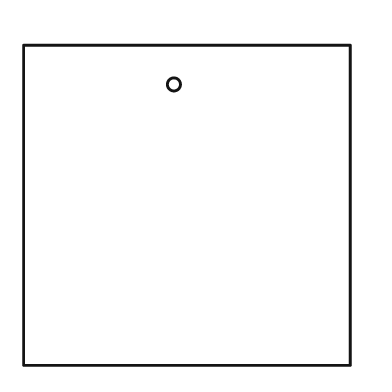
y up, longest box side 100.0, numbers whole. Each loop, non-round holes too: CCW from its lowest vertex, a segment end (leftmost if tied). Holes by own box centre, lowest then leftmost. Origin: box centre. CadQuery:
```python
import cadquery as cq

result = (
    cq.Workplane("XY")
    .moveTo(-50.0, -49.0)
    .lineTo(50.0, -49.0)
    .lineTo(50.0, 49.0)
    .lineTo(-50.0, 49.0)
    .close()
    .moveTo(-4.0, 37.0)
    .circle(2.0)
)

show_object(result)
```